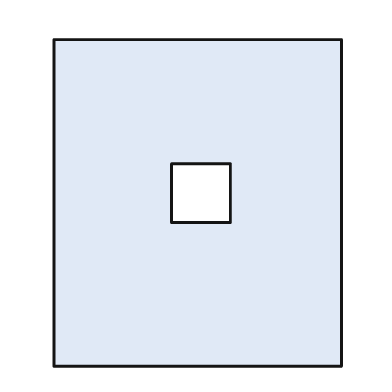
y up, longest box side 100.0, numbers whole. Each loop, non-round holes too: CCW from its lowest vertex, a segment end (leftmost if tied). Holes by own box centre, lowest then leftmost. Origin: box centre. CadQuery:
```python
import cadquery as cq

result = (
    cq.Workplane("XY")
    .moveTo(-44.0, -50.0)
    .lineTo(44.0, -50.0)
    .lineTo(44.0, 50.0)
    .lineTo(-44.0, 50.0)
    .close()
    .moveTo(-8.0, -6.0)
    .lineTo(10.0, -6.0)
    .lineTo(10.0, 12.0)
    .lineTo(-8.0, 12.0)
    .close()
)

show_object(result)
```